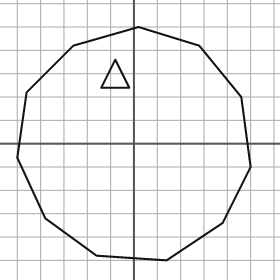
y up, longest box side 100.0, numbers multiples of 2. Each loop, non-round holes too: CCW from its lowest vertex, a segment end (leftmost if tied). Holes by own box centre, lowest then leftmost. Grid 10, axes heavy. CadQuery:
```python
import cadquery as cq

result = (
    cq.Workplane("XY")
    .moveTo(14.0, -50.0)
    .lineTo(38.0, -34.0)
    .lineTo(50.0, -10.0)
    .lineTo(46.0, 20.0)
    .lineTo(28.0, 42.0)
    .lineTo(2.0, 50.0)
    .lineTo(-26.0, 42.0)
    .lineTo(-46.0, 22.0)
    .lineTo(-50.0, -6.0)
    .lineTo(-38.0, -32.0)
    .lineTo(-16.0, -48.0)
    .close()
    .moveTo(-14.0, 24.0)
    .lineTo(-2.0, 24.0)
    .lineTo(-8.0, 36.0)
    .close()
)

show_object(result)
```